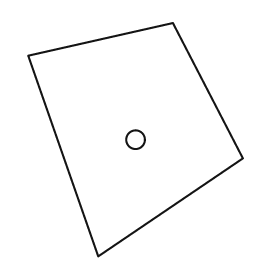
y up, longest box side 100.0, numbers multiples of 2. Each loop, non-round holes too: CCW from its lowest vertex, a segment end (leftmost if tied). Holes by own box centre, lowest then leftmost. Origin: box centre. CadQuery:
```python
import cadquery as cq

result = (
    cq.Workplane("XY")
    .moveTo(-16.0, -50.0)
    .lineTo(46.0, -8.0)
    .lineTo(16.0, 50.0)
    .lineTo(-46.0, 36.0)
    .close()
    .moveTo(0.0, 0.0)
    .circle(4.0)
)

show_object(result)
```